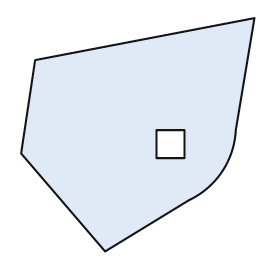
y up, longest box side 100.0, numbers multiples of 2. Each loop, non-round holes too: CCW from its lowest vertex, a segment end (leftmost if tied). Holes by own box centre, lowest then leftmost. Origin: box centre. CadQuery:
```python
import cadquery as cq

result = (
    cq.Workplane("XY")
    .moveTo(-14.0, -50.0)
    .lineTo(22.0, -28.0)
    .threePointArc((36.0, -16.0), (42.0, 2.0))
    .lineTo(50.0, 50.0)
    .lineTo(-44.0, 32.0)
    .lineTo(-50.0, -8.0)
    .close()
    .moveTo(8.0, -10.0)
    .lineTo(20.0, -10.0)
    .lineTo(20.0, 2.0)
    .lineTo(8.0, 2.0)
    .close()
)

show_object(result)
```